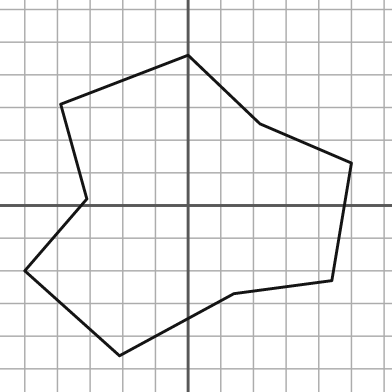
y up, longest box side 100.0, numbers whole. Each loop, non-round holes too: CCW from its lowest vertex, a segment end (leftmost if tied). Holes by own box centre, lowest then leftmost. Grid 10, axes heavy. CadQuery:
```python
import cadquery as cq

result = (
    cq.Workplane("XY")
    .moveTo(-21.0, -46.0)
    .lineTo(14.0, -27.0)
    .lineTo(44.0, -23.0)
    .lineTo(50.0, 13.0)
    .lineTo(22.0, 25.0)
    .lineTo(0.0, 46.0)
    .lineTo(-39.0, 31.0)
    .lineTo(-31.0, 2.0)
    .lineTo(-50.0, -20.0)
    .close()
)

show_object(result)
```